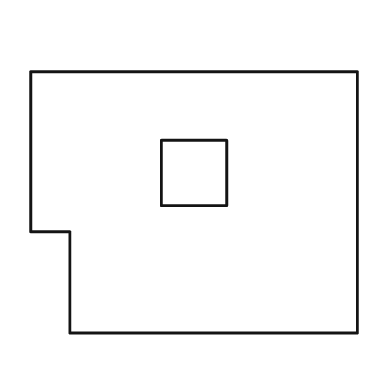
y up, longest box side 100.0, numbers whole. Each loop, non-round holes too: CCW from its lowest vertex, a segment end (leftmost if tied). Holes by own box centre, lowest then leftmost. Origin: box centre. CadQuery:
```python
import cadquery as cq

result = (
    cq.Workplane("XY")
    .moveTo(-38.0, -40.0)
    .lineTo(50.0, -40.0)
    .lineTo(50.0, 40.0)
    .lineTo(-50.0, 40.0)
    .lineTo(-50.0, -9.0)
    .lineTo(-38.0, -9.0)
    .close()
    .moveTo(-10.0, -1.0)
    .lineTo(10.0, -1.0)
    .lineTo(10.0, 19.0)
    .lineTo(-10.0, 19.0)
    .close()
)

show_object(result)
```